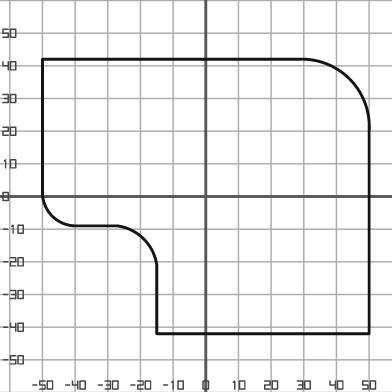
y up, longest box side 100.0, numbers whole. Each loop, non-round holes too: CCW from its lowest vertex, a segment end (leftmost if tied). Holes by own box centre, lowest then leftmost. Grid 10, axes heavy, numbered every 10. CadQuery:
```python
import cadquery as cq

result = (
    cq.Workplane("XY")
    .moveTo(-15.0, -42.0)
    .lineTo(50.0, -42.0)
    .lineTo(50.0, 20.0)
    .threePointArc((44.0, 36.0), (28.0, 42.0))
    .lineTo(-50.0, 42.0)
    .lineTo(-50.0, 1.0)
    .threePointArc((-47.0, -6.0), (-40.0, -9.0))
    .lineTo(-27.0, -9.0)
    .threePointArc((-19.0, -13.0), (-15.0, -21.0))
    .close()
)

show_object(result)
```